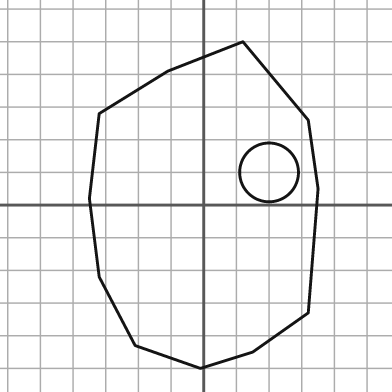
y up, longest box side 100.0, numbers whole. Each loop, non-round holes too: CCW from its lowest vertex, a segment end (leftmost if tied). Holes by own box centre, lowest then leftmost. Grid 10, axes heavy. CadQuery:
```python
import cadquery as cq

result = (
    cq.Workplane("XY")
    .moveTo(-1.0, -50.0)
    .lineTo(15.0, -45.0)
    .lineTo(32.0, -33.0)
    .lineTo(35.0, 5.0)
    .lineTo(32.0, 26.0)
    .lineTo(12.0, 50.0)
    .lineTo(-11.0, 41.0)
    .lineTo(-32.0, 28.0)
    .lineTo(-35.0, 2.0)
    .lineTo(-32.0, -22.0)
    .lineTo(-21.0, -43.0)
    .close()
    .moveTo(20.0, 10.0)
    .circle(9.0)
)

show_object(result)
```